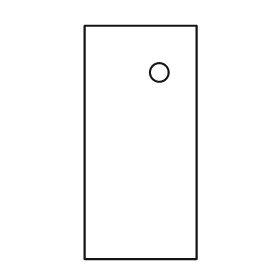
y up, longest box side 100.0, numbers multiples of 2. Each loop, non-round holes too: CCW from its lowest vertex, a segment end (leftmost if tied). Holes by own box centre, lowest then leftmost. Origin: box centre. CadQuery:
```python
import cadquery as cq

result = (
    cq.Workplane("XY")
    .moveTo(-24.0, -50.0)
    .lineTo(24.0, -50.0)
    .lineTo(24.0, 50.0)
    .lineTo(-24.0, 50.0)
    .close()
    .moveTo(8.0, 30.0)
    .circle(4.0)
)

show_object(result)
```